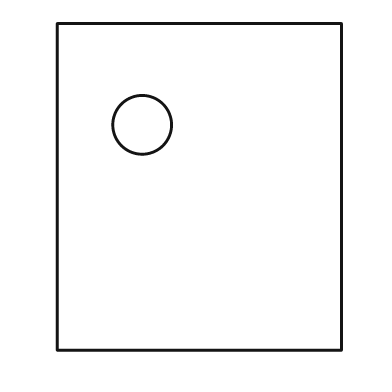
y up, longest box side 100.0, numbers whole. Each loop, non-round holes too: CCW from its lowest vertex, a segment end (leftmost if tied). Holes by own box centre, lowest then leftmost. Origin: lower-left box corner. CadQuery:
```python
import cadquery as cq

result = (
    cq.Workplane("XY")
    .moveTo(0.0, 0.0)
    .lineTo(87.0, 0.0)
    .lineTo(87.0, 100.0)
    .lineTo(0.0, 100.0)
    .close()
    .moveTo(26.0, 69.0)
    .circle(9.0)
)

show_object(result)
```